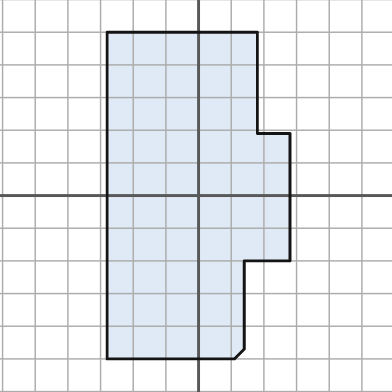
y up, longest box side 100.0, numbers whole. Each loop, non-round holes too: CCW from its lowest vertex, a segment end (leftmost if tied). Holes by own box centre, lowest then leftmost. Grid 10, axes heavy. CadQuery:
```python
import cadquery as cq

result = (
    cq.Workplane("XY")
    .moveTo(-28.0, -50.0)
    .lineTo(11.0, -50.0)
    .lineTo(14.0, -47.0)
    .lineTo(14.0, -20.0)
    .lineTo(28.0, -20.0)
    .lineTo(28.0, 19.0)
    .lineTo(18.0, 19.0)
    .lineTo(18.0, 50.0)
    .lineTo(-28.0, 50.0)
    .close()
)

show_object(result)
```